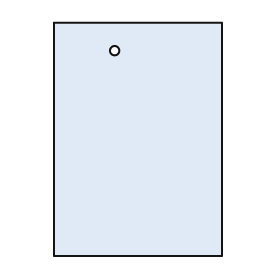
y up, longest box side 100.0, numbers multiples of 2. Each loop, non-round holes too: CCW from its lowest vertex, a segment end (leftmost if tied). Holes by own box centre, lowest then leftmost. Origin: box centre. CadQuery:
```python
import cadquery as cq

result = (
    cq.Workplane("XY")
    .moveTo(-36.0, -50.0)
    .lineTo(36.0, -50.0)
    .lineTo(36.0, 50.0)
    .lineTo(-36.0, 50.0)
    .close()
    .moveTo(-10.0, 38.0)
    .circle(2.0)
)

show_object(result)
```